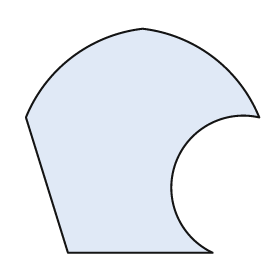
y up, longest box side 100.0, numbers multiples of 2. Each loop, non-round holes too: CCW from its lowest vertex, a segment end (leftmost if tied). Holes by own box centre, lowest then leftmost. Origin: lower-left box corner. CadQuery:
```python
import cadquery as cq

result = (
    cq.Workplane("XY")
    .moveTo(18.0, 0.0)
    .lineTo(80.0, 0.0)
    .threePointArc((64.0, 38.0), (100.0, 58.0))
    .threePointArc((80.0, 84.0), (50.0, 96.0))
    .threePointArc((20.0, 84.0), (0.0, 58.0))
    .close()
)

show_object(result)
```